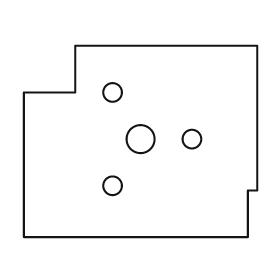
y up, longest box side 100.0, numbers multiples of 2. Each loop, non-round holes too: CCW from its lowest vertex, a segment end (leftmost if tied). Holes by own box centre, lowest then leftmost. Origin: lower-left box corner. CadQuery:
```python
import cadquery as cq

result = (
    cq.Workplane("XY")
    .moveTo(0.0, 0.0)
    .lineTo(96.0, 0.0)
    .lineTo(96.0, 20.0)
    .lineTo(100.0, 20.0)
    .lineTo(100.0, 82.0)
    .lineTo(22.0, 82.0)
    .lineTo(22.0, 62.0)
    .lineTo(0.0, 62.0)
    .close()
    .moveTo(38.0, 22.0)
    .circle(4.0)
    .moveTo(50.0, 42.0)
    .circle(6.0)
    .moveTo(72.0, 42.0)
    .circle(4.0)
    .moveTo(38.0, 62.0)
    .circle(4.0)
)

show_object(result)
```